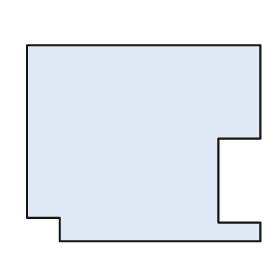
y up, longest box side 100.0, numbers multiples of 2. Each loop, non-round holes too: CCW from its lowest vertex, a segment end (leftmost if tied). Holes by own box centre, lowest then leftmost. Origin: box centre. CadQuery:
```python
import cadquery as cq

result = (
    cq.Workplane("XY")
    .moveTo(-36.0, -42.0)
    .lineTo(50.0, -42.0)
    .lineTo(50.0, -34.0)
    .lineTo(32.0, -34.0)
    .lineTo(32.0, 2.0)
    .lineTo(50.0, 2.0)
    .lineTo(50.0, 42.0)
    .lineTo(-50.0, 42.0)
    .lineTo(-50.0, -32.0)
    .lineTo(-36.0, -32.0)
    .close()
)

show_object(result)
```